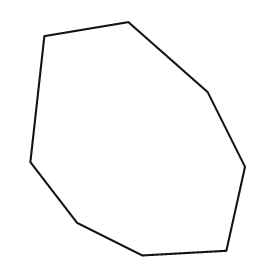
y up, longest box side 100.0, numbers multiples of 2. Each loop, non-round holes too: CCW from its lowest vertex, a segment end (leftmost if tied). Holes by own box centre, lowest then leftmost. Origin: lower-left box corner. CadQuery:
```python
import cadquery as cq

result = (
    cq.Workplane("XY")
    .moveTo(48.0, 0.0)
    .lineTo(84.0, 2.0)
    .lineTo(92.0, 38.0)
    .lineTo(76.0, 70.0)
    .lineTo(42.0, 100.0)
    .lineTo(6.0, 94.0)
    .lineTo(0.0, 40.0)
    .lineTo(20.0, 14.0)
    .close()
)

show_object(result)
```